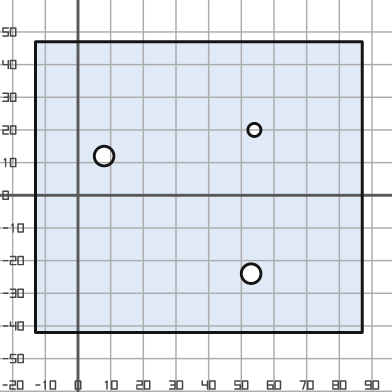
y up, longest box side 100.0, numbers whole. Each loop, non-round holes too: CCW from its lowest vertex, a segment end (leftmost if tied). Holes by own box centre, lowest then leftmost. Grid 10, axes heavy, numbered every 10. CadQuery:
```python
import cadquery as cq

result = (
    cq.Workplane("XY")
    .moveTo(-13.0, -42.0)
    .lineTo(87.0, -42.0)
    .lineTo(87.0, 47.0)
    .lineTo(-13.0, 47.0)
    .close()
    .moveTo(53.0, -24.0)
    .circle(3.0)
    .moveTo(8.0, 12.0)
    .circle(3.0)
    .moveTo(54.0, 20.0)
    .circle(2.0)
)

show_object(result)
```